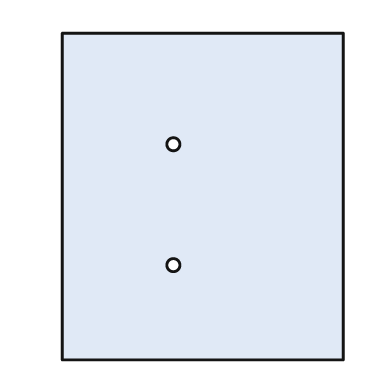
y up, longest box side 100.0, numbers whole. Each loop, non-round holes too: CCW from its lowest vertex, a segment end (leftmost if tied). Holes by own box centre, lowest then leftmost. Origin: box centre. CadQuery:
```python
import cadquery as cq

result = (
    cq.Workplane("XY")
    .moveTo(-43.0, -50.0)
    .lineTo(43.0, -50.0)
    .lineTo(43.0, 50.0)
    .lineTo(-43.0, 50.0)
    .close()
    .moveTo(-9.0, -21.0)
    .circle(2.0)
    .moveTo(-9.0, 16.0)
    .circle(2.0)
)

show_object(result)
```